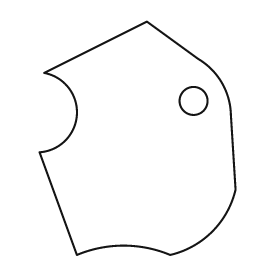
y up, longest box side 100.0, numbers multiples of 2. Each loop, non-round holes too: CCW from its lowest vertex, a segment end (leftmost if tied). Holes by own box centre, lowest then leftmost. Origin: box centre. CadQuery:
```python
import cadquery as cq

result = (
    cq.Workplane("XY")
    .moveTo(-26.0, -50.0)
    .threePointArc((-6.0, -46.0), (14.0, -50.0))
    .threePointArc((32.0, -40.0), (42.0, -22.0))
    .lineTo(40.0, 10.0)
    .threePointArc((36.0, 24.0), (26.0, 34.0))
    .lineTo(4.0, 50.0)
    .lineTo(-40.0, 28.0)
    .threePointArc((-26.0, 10.0), (-42.0, -6.0))
    .close()
    .moveTo(24.0, 16.0)
    .circle(6.0)
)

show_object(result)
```